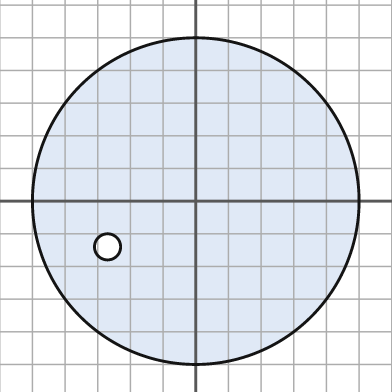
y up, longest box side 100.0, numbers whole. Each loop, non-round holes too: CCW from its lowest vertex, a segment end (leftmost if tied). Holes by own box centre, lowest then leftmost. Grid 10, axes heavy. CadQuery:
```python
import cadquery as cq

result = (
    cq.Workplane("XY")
    .moveTo(0.0, 0.0)
    .circle(50.0)
    .moveTo(-27.0, -14.0)
    .circle(4.0)
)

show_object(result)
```